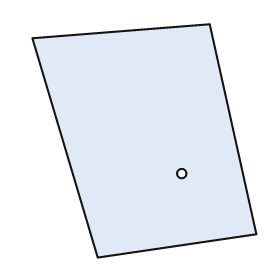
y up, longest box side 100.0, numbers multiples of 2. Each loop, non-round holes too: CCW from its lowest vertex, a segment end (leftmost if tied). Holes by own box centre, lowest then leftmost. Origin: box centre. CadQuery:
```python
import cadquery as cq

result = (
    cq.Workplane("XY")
    .moveTo(-20.0, -50.0)
    .lineTo(48.0, -40.0)
    .lineTo(28.0, 50.0)
    .lineTo(-48.0, 44.0)
    .close()
    .moveTo(16.0, -14.0)
    .circle(2.0)
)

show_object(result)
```